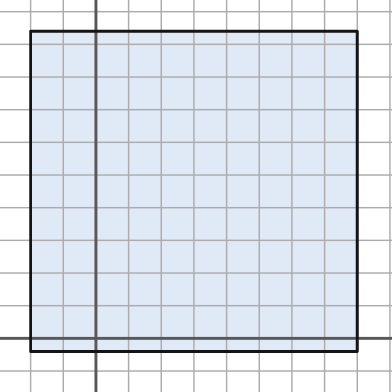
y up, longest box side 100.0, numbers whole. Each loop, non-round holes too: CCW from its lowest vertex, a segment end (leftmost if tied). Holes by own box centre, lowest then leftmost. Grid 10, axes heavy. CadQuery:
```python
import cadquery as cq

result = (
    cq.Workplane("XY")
    .moveTo(-20.0, -4.0)
    .lineTo(80.0, -4.0)
    .lineTo(80.0, 94.0)
    .lineTo(-20.0, 94.0)
    .close()
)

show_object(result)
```